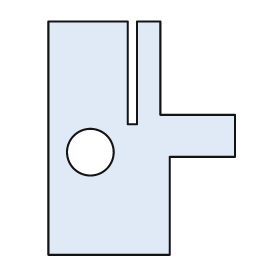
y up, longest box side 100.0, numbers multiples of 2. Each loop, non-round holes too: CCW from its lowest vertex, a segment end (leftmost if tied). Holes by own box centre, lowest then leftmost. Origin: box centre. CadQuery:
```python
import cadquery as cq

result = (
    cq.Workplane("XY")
    .moveTo(-40.0, -50.0)
    .lineTo(12.0, -50.0)
    .lineTo(12.0, -8.0)
    .lineTo(40.0, -8.0)
    .lineTo(40.0, 10.0)
    .lineTo(8.0, 10.0)
    .lineTo(8.0, 50.0)
    .lineTo(-2.0, 50.0)
    .lineTo(-2.0, 6.0)
    .lineTo(-6.0, 6.0)
    .lineTo(-6.0, 50.0)
    .lineTo(-40.0, 50.0)
    .close()
    .moveTo(-22.0, -6.0)
    .circle(10.0)
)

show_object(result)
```